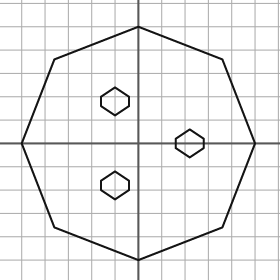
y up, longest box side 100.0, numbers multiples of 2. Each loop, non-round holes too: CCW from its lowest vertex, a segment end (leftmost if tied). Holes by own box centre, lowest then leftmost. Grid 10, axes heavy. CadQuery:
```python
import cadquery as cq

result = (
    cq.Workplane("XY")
    .moveTo(0.0, -50.0)
    .lineTo(36.0, -36.0)
    .lineTo(50.0, 0.0)
    .lineTo(36.0, 36.0)
    .lineTo(0.0, 50.0)
    .lineTo(-36.0, 36.0)
    .lineTo(-50.0, 0.0)
    .lineTo(-36.0, -36.0)
    .close()
    .moveTo(-10.0, -24.0)
    .lineTo(-4.0, -20.0)
    .lineTo(-4.0, -16.0)
    .lineTo(-10.0, -12.0)
    .lineTo(-16.0, -16.0)
    .lineTo(-16.0, -20.0)
    .close()
    .moveTo(22.0, -6.0)
    .lineTo(28.0, -2.0)
    .lineTo(28.0, 2.0)
    .lineTo(22.0, 6.0)
    .lineTo(16.0, 2.0)
    .lineTo(16.0, -2.0)
    .close()
    .moveTo(-10.0, 12.0)
    .lineTo(-4.0, 16.0)
    .lineTo(-4.0, 20.0)
    .lineTo(-10.0, 24.0)
    .lineTo(-16.0, 20.0)
    .lineTo(-16.0, 16.0)
    .close()
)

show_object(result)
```